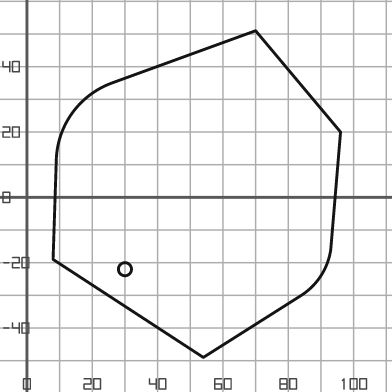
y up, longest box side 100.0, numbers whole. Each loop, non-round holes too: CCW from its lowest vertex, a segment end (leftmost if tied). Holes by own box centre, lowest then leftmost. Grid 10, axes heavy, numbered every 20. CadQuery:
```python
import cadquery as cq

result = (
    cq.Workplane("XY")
    .moveTo(54.0, -49.0)
    .lineTo(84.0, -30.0)
    .threePointArc((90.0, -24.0), (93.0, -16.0))
    .lineTo(96.0, 20.0)
    .lineTo(70.0, 51.0)
    .lineTo(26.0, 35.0)
    .threePointArc((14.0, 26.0), (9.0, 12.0))
    .lineTo(8.0, -19.0)
    .close()
    .moveTo(30.0, -22.0)
    .circle(2.0)
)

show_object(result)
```